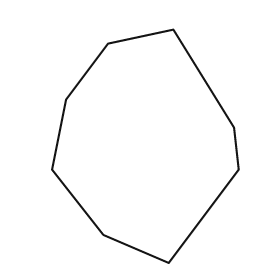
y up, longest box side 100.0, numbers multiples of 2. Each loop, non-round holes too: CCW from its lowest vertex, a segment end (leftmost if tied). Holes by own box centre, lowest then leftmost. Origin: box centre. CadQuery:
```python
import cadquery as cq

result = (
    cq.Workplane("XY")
    .moveTo(10.0, -50.0)
    .lineTo(40.0, -10.0)
    .lineTo(38.0, 8.0)
    .lineTo(12.0, 50.0)
    .lineTo(-16.0, 44.0)
    .lineTo(-34.0, 20.0)
    .lineTo(-40.0, -10.0)
    .lineTo(-18.0, -38.0)
    .close()
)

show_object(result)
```